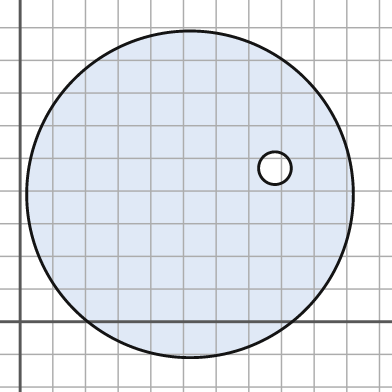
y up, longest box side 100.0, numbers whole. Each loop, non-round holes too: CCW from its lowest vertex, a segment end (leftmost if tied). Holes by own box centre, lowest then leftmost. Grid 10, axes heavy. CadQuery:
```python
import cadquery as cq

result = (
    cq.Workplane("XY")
    .moveTo(52.0, 39.0)
    .circle(50.0)
    .moveTo(78.0, 47.0)
    .circle(5.0)
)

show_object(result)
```